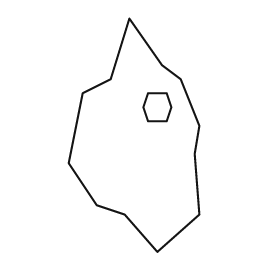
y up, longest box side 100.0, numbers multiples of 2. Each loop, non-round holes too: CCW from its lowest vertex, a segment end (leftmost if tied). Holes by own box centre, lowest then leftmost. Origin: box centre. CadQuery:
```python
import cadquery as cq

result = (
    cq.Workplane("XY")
    .moveTo(10.0, -50.0)
    .lineTo(28.0, -34.0)
    .lineTo(26.0, -8.0)
    .lineTo(28.0, 4.0)
    .lineTo(20.0, 24.0)
    .lineTo(12.0, 30.0)
    .lineTo(-2.0, 50.0)
    .lineTo(-10.0, 24.0)
    .lineTo(-22.0, 18.0)
    .lineTo(-28.0, -12.0)
    .lineTo(-16.0, -30.0)
    .lineTo(-4.0, -34.0)
    .close()
    .moveTo(6.0, 6.0)
    .lineTo(14.0, 6.0)
    .lineTo(16.0, 12.0)
    .lineTo(14.0, 18.0)
    .lineTo(6.0, 18.0)
    .lineTo(4.0, 12.0)
    .close()
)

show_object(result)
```